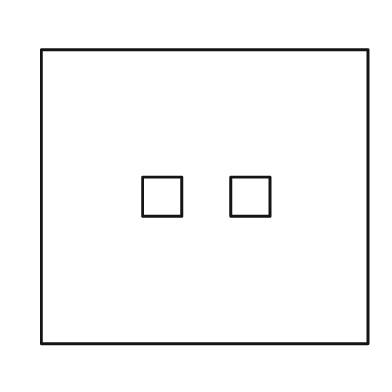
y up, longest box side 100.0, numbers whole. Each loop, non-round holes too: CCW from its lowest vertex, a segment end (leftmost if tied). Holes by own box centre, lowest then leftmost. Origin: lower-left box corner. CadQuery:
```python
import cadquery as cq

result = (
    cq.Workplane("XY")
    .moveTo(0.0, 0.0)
    .lineTo(100.0, 0.0)
    .lineTo(100.0, 90.0)
    .lineTo(0.0, 90.0)
    .close()
    .moveTo(31.0, 39.0)
    .lineTo(43.0, 39.0)
    .lineTo(43.0, 51.0)
    .lineTo(31.0, 51.0)
    .close()
    .moveTo(58.0, 39.0)
    .lineTo(70.0, 39.0)
    .lineTo(70.0, 51.0)
    .lineTo(58.0, 51.0)
    .close()
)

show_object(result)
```